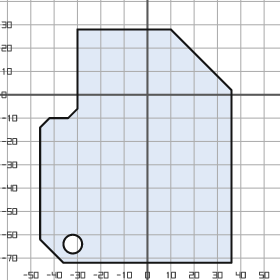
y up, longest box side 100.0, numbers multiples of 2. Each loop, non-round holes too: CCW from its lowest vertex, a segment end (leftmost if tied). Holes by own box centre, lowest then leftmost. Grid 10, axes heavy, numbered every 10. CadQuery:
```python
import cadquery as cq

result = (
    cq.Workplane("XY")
    .moveTo(-36.0, -72.0)
    .lineTo(36.0, -72.0)
    .lineTo(36.0, 2.0)
    .lineTo(10.0, 28.0)
    .lineTo(-30.0, 28.0)
    .lineTo(-30.0, -6.0)
    .lineTo(-34.0, -10.0)
    .lineTo(-42.0, -10.0)
    .lineTo(-46.0, -14.0)
    .lineTo(-46.0, -62.0)
    .close()
    .moveTo(-32.0, -64.0)
    .circle(4.0)
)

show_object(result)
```